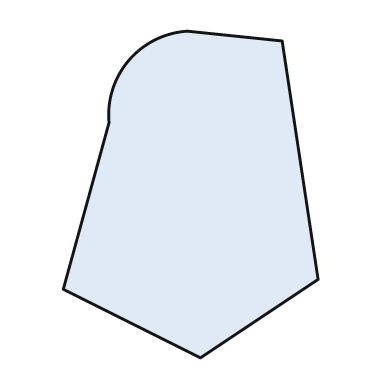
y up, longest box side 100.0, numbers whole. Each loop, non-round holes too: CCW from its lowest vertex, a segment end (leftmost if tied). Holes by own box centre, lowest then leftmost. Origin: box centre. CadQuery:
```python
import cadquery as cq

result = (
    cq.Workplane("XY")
    .moveTo(3.0, -50.0)
    .lineTo(39.0, -26.0)
    .lineTo(28.0, 47.0)
    .lineTo(-1.0, 50.0)
    .threePointArc((-19.0, 41.0), (-25.0, 22.0))
    .lineTo(-39.0, -29.0)
    .close()
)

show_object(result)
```